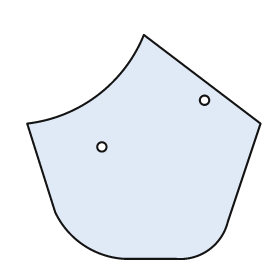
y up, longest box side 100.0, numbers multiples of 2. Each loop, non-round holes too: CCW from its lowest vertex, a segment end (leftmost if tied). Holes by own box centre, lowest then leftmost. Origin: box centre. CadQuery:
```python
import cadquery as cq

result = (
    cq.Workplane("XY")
    .moveTo(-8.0, -48.0)
    .lineTo(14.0, -48.0)
    .threePointArc((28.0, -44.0), (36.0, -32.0))
    .lineTo(50.0, 10.0)
    .lineTo(0.0, 48.0)
    .threePointArc((-20.0, 22.0), (-50.0, 10.0))
    .lineTo(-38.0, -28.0)
    .threePointArc((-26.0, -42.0), (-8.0, -48.0))
    .close()
    .moveTo(-18.0, 0.0)
    .circle(2.0)
    .moveTo(26.0, 20.0)
    .circle(2.0)
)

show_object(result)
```